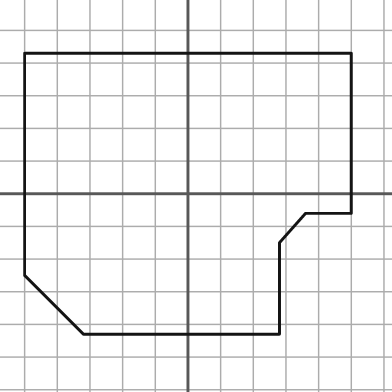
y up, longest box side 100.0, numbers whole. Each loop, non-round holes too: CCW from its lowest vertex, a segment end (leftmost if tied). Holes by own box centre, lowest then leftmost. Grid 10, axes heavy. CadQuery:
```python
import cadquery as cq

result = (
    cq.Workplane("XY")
    .moveTo(-32.0, -43.0)
    .lineTo(28.0, -43.0)
    .lineTo(28.0, -15.0)
    .lineTo(36.0, -6.0)
    .lineTo(50.0, -6.0)
    .lineTo(50.0, 43.0)
    .lineTo(-50.0, 43.0)
    .lineTo(-50.0, -25.0)
    .close()
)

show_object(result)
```